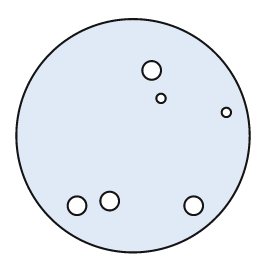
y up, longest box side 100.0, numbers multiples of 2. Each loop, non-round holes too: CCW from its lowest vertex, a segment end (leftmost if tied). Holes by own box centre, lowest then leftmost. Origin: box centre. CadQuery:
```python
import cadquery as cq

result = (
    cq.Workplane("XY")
    .moveTo(0.0, 0.0)
    .circle(50.0)
    .moveTo(-24.0, -30.0)
    .circle(4.0)
    .moveTo(26.0, -30.0)
    .circle(4.0)
    .moveTo(-10.0, -28.0)
    .circle(4.0)
    .moveTo(40.0, 10.0)
    .circle(2.0)
    .moveTo(12.0, 16.0)
    .circle(2.0)
    .moveTo(8.0, 28.0)
    .circle(4.0)
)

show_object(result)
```